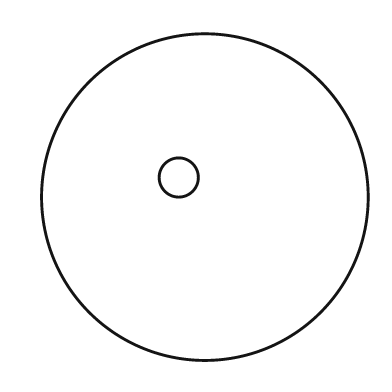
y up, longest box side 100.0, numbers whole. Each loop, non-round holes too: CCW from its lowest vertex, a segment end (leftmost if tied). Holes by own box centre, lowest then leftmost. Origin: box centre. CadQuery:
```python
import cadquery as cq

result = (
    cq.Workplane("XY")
    .moveTo(0.0, 0.0)
    .circle(50.0)
    .moveTo(-8.0, 6.0)
    .circle(6.0)
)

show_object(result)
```